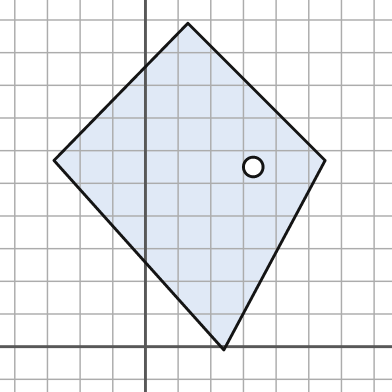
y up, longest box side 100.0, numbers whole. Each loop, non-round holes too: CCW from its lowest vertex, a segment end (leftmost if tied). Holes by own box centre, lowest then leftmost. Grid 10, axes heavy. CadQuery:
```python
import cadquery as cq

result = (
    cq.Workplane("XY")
    .moveTo(24.0, -1.0)
    .lineTo(55.0, 57.0)
    .lineTo(13.0, 99.0)
    .lineTo(-28.0, 57.0)
    .close()
    .moveTo(33.0, 55.0)
    .circle(3.0)
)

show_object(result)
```